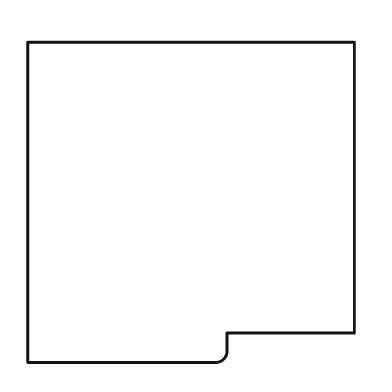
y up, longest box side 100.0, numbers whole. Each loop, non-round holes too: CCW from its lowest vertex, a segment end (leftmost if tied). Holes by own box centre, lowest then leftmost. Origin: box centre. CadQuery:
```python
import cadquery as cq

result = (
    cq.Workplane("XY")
    .moveTo(-50.0, -49.0)
    .lineTo(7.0, -49.0)
    .threePointArc((10.0, -48.0), (11.0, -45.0))
    .lineTo(11.0, -40.0)
    .lineTo(50.0, -40.0)
    .lineTo(50.0, 49.0)
    .lineTo(-50.0, 49.0)
    .close()
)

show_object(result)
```